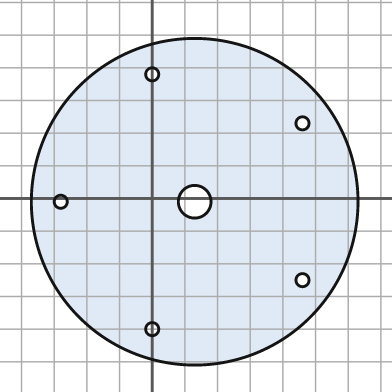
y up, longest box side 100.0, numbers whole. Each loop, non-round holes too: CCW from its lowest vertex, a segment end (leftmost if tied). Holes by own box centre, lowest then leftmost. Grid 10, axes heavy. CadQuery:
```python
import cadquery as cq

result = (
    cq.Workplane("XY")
    .moveTo(13.0, -1.0)
    .circle(50.0)
    .moveTo(0.0, -40.0)
    .circle(2.0)
    .moveTo(46.0, -25.0)
    .circle(2.0)
    .moveTo(-28.0, -1.0)
    .circle(2.0)
    .moveTo(13.0, -1.0)
    .circle(5.0)
    .moveTo(46.0, 23.0)
    .circle(2.0)
    .moveTo(0.0, 38.0)
    .circle(2.0)
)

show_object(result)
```